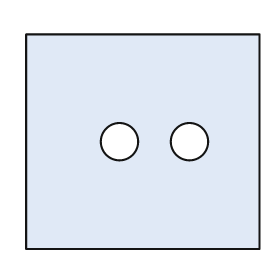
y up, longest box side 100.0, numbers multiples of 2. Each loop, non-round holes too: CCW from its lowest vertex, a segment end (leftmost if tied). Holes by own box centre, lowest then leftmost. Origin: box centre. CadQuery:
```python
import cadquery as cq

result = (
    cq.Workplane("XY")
    .moveTo(-50.0, -46.0)
    .lineTo(50.0, -46.0)
    .lineTo(50.0, 46.0)
    .lineTo(-50.0, 46.0)
    .close()
    .moveTo(-10.0, 0.0)
    .circle(8.0)
    .moveTo(20.0, 0.0)
    .circle(8.0)
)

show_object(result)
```